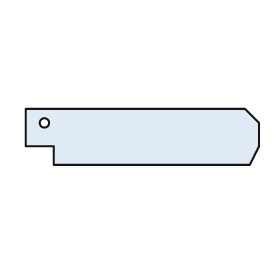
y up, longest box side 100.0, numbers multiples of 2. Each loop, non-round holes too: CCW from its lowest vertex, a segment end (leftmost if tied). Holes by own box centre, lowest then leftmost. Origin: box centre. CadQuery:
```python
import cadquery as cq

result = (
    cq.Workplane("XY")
    .moveTo(-38.0, -12.0)
    .lineTo(46.0, -12.0)
    .lineTo(50.0, -4.0)
    .lineTo(50.0, 6.0)
    .lineTo(44.0, 12.0)
    .lineTo(-50.0, 12.0)
    .lineTo(-50.0, -4.0)
    .lineTo(-38.0, -4.0)
    .close()
    .moveTo(-42.0, 6.0)
    .circle(2.0)
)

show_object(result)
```